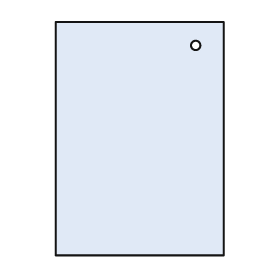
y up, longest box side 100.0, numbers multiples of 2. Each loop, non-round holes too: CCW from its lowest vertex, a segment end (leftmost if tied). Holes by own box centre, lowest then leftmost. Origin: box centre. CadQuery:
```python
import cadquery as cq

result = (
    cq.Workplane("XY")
    .moveTo(-36.0, -50.0)
    .lineTo(36.0, -50.0)
    .lineTo(36.0, 50.0)
    .lineTo(-36.0, 50.0)
    .close()
    .moveTo(24.0, 40.0)
    .circle(2.0)
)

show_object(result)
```